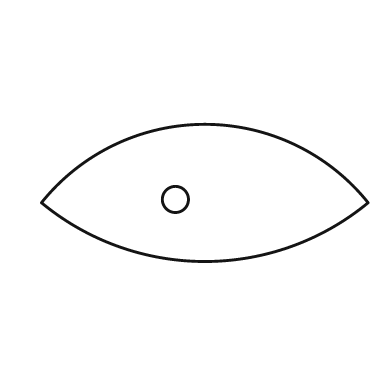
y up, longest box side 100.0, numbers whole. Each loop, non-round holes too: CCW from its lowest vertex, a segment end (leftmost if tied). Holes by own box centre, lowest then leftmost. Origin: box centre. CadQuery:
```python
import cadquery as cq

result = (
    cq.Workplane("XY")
    .moveTo(-50.0, -3.0)
    .threePointArc((0.0, -21.0), (50.0, -3.0))
    .threePointArc((0.0, 21.0), (-50.0, -3.0))
    .close()
    .moveTo(-9.0, -2.0)
    .circle(4.0)
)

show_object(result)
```